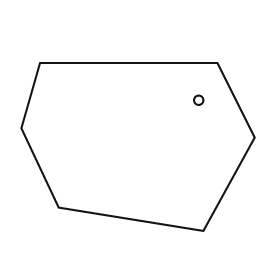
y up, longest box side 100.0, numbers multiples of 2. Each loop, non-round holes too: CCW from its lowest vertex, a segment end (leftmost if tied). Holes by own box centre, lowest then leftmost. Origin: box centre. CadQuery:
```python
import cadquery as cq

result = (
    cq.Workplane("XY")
    .moveTo(28.0, -36.0)
    .lineTo(50.0, 4.0)
    .lineTo(34.0, 36.0)
    .lineTo(-42.0, 36.0)
    .lineTo(-50.0, 8.0)
    .lineTo(-34.0, -26.0)
    .close()
    .moveTo(26.0, 20.0)
    .circle(2.0)
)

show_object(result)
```